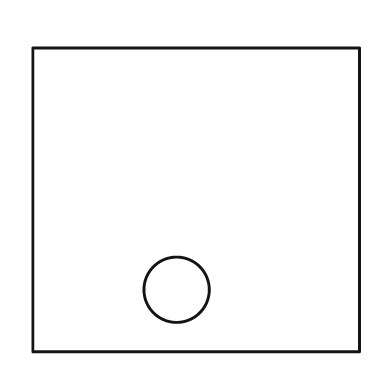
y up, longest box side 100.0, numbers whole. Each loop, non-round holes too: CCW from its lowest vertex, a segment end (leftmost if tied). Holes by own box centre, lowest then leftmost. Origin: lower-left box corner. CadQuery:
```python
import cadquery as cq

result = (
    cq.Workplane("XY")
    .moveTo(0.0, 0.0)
    .lineTo(100.0, 0.0)
    .lineTo(100.0, 93.0)
    .lineTo(0.0, 93.0)
    .close()
    .moveTo(44.0, 19.0)
    .circle(10.0)
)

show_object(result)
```